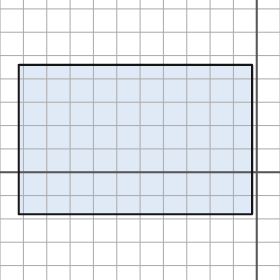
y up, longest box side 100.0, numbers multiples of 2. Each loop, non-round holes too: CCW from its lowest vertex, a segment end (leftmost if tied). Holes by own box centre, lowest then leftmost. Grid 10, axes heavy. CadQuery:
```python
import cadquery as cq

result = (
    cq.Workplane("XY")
    .moveTo(-102.0, -18.0)
    .lineTo(-2.0, -18.0)
    .lineTo(-2.0, 46.0)
    .lineTo(-102.0, 46.0)
    .close()
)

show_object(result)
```